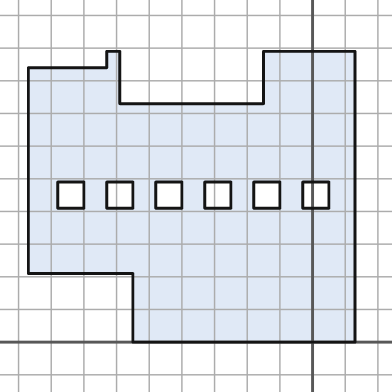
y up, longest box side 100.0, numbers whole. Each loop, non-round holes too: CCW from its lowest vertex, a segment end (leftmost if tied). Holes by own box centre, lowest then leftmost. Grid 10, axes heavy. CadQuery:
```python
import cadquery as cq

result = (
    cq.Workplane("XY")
    .moveTo(-55.0, 0.0)
    .lineTo(13.0, 0.0)
    .lineTo(13.0, 89.0)
    .lineTo(-15.0, 89.0)
    .lineTo(-15.0, 73.0)
    .lineTo(-59.0, 73.0)
    .lineTo(-59.0, 89.0)
    .lineTo(-63.0, 89.0)
    .lineTo(-63.0, 84.0)
    .lineTo(-87.0, 84.0)
    .lineTo(-87.0, 21.0)
    .lineTo(-55.0, 21.0)
    .close()
    .moveTo(-78.0, 41.0)
    .lineTo(-70.0, 41.0)
    .lineTo(-70.0, 49.0)
    .lineTo(-78.0, 49.0)
    .close()
    .moveTo(-63.0, 41.0)
    .lineTo(-55.0, 41.0)
    .lineTo(-55.0, 49.0)
    .lineTo(-63.0, 49.0)
    .close()
    .moveTo(-48.0, 41.0)
    .lineTo(-40.0, 41.0)
    .lineTo(-40.0, 49.0)
    .lineTo(-48.0, 49.0)
    .close()
    .moveTo(-33.0, 41.0)
    .lineTo(-25.0, 41.0)
    .lineTo(-25.0, 49.0)
    .lineTo(-33.0, 49.0)
    .close()
    .moveTo(-18.0, 41.0)
    .lineTo(-10.0, 41.0)
    .lineTo(-10.0, 49.0)
    .lineTo(-18.0, 49.0)
    .close()
    .moveTo(-3.0, 41.0)
    .lineTo(5.0, 41.0)
    .lineTo(5.0, 49.0)
    .lineTo(-3.0, 49.0)
    .close()
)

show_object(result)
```